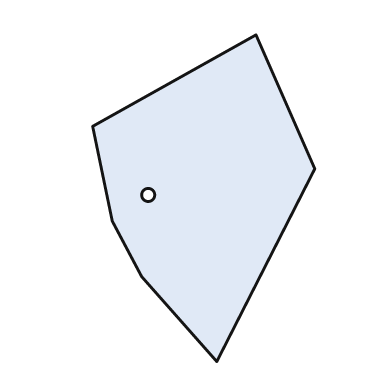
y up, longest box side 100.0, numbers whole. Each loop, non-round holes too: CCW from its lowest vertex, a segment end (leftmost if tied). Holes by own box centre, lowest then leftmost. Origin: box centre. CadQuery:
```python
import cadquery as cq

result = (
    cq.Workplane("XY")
    .moveTo(4.0, -50.0)
    .lineTo(34.0, 9.0)
    .lineTo(16.0, 50.0)
    .lineTo(-34.0, 22.0)
    .lineTo(-28.0, -7.0)
    .lineTo(-19.0, -24.0)
    .close()
    .moveTo(-17.0, 1.0)
    .circle(2.0)
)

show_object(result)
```